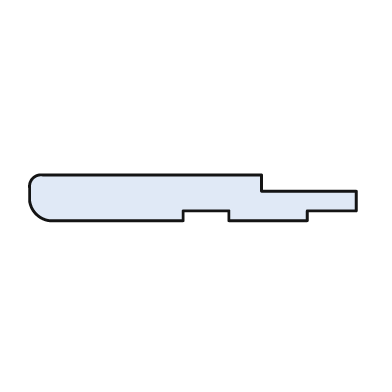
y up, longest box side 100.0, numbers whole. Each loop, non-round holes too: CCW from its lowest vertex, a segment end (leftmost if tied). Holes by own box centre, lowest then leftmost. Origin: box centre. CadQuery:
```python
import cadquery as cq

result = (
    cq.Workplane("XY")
    .moveTo(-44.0, -7.0)
    .lineTo(-3.0, -7.0)
    .lineTo(-3.0, -4.0)
    .lineTo(11.0, -4.0)
    .lineTo(11.0, -7.0)
    .lineTo(35.0, -7.0)
    .lineTo(35.0, -4.0)
    .lineTo(50.0, -4.0)
    .lineTo(50.0, 2.0)
    .lineTo(21.0, 2.0)
    .lineTo(21.0, 7.0)
    .lineTo(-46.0, 7.0)
    .threePointArc((-49.0, 6.0), (-50.0, 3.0))
    .lineTo(-50.0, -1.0)
    .threePointArc((-48.0, -5.0), (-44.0, -7.0))
    .close()
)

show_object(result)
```